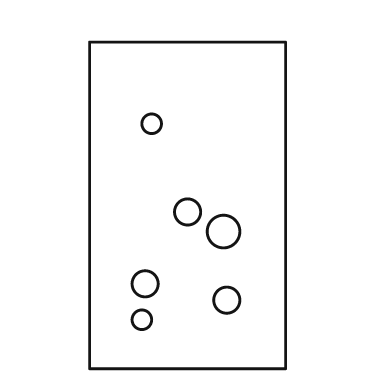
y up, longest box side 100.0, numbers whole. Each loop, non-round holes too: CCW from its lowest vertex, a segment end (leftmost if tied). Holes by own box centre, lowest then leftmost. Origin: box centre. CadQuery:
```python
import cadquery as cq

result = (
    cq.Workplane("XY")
    .moveTo(-30.0, -50.0)
    .lineTo(30.0, -50.0)
    .lineTo(30.0, 50.0)
    .lineTo(-30.0, 50.0)
    .close()
    .moveTo(-14.0, -35.0)
    .circle(3.0)
    .moveTo(12.0, -29.0)
    .circle(4.0)
    .moveTo(-13.0, -24.0)
    .circle(4.0)
    .moveTo(11.0, -8.0)
    .circle(5.0)
    .moveTo(0.0, -2.0)
    .circle(4.0)
    .moveTo(-11.0, 25.0)
    .circle(3.0)
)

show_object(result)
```